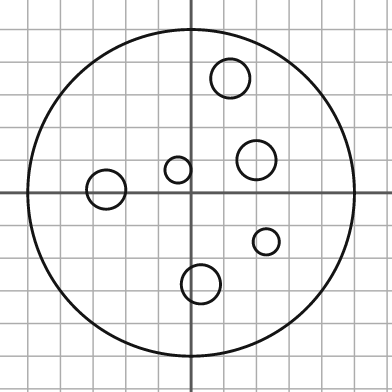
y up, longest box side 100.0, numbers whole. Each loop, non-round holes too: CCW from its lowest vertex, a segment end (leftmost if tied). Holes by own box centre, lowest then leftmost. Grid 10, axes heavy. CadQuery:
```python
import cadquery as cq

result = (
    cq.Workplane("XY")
    .moveTo(0.0, 0.0)
    .circle(50.0)
    .moveTo(3.0, -28.0)
    .circle(6.0)
    .moveTo(23.0, -15.0)
    .circle(4.0)
    .moveTo(-26.0, 1.0)
    .circle(6.0)
    .moveTo(-4.0, 7.0)
    .circle(4.0)
    .moveTo(20.0, 10.0)
    .circle(6.0)
    .moveTo(12.0, 35.0)
    .circle(6.0)
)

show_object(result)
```